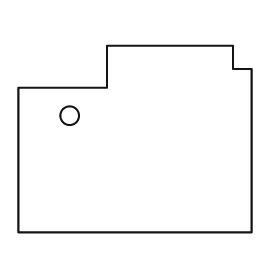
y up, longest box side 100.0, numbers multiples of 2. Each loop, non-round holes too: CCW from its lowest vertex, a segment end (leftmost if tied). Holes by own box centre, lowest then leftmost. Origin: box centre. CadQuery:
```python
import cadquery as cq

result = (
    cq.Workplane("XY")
    .moveTo(-50.0, -40.0)
    .lineTo(50.0, -40.0)
    .lineTo(50.0, 30.0)
    .lineTo(42.0, 30.0)
    .lineTo(42.0, 40.0)
    .lineTo(-12.0, 40.0)
    .lineTo(-12.0, 22.0)
    .lineTo(-50.0, 22.0)
    .close()
    .moveTo(-28.0, 10.0)
    .circle(4.0)
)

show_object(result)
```